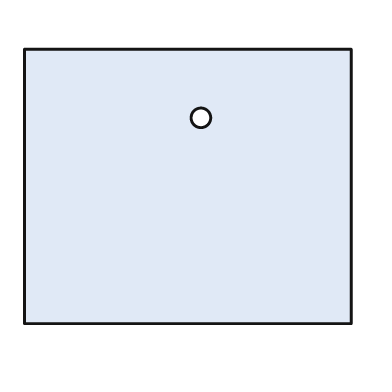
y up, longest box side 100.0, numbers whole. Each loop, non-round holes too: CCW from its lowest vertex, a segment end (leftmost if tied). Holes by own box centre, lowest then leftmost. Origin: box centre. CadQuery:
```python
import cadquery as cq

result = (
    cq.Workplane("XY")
    .moveTo(-50.0, -42.0)
    .lineTo(50.0, -42.0)
    .lineTo(50.0, 42.0)
    .lineTo(-50.0, 42.0)
    .close()
    .moveTo(4.0, 21.0)
    .circle(3.0)
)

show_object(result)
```